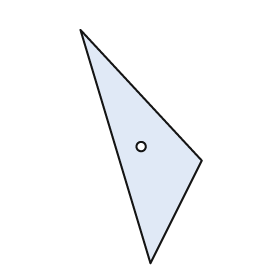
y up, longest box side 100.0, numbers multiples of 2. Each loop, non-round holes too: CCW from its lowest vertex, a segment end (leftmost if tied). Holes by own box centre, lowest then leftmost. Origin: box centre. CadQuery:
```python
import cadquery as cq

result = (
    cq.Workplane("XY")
    .moveTo(4.0, -50.0)
    .lineTo(26.0, -6.0)
    .lineTo(-26.0, 50.0)
    .close()
    .moveTo(0.0, 0.0)
    .circle(2.0)
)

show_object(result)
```